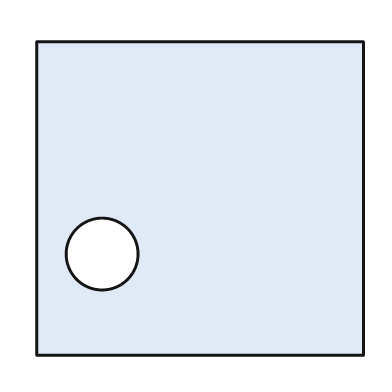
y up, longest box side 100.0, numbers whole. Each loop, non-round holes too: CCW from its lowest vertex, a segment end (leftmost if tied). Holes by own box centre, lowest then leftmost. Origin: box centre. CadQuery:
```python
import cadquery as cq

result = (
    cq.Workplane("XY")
    .moveTo(-50.0, -48.0)
    .lineTo(50.0, -48.0)
    .lineTo(50.0, 48.0)
    .lineTo(-50.0, 48.0)
    .close()
    .moveTo(-30.0, -17.0)
    .circle(11.0)
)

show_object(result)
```